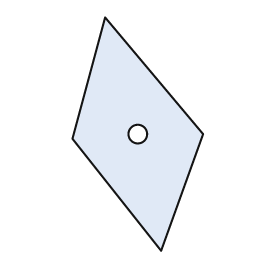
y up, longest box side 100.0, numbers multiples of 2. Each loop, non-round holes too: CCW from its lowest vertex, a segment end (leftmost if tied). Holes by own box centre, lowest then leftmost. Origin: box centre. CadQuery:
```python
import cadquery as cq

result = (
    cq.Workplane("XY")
    .moveTo(10.0, -50.0)
    .lineTo(28.0, 0.0)
    .lineTo(-14.0, 50.0)
    .lineTo(-28.0, -2.0)
    .close()
    .moveTo(0.0, 0.0)
    .circle(4.0)
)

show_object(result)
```